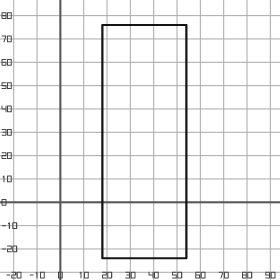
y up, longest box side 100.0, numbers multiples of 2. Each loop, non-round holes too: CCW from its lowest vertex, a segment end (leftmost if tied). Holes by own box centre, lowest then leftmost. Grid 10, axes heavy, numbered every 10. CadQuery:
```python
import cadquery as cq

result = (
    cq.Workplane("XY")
    .moveTo(18.0, -24.0)
    .lineTo(54.0, -24.0)
    .lineTo(54.0, 76.0)
    .lineTo(18.0, 76.0)
    .close()
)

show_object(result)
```